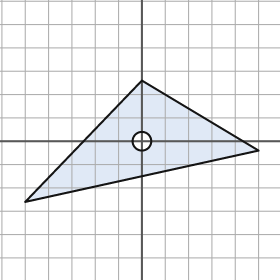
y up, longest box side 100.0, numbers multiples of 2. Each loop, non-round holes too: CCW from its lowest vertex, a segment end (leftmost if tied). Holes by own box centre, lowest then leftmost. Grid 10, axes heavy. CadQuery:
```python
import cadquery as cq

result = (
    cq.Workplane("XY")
    .moveTo(-50.0, -26.0)
    .lineTo(50.0, -4.0)
    .lineTo(0.0, 26.0)
    .close()
    .moveTo(0.0, 0.0)
    .circle(4.0)
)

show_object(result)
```